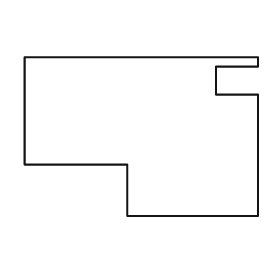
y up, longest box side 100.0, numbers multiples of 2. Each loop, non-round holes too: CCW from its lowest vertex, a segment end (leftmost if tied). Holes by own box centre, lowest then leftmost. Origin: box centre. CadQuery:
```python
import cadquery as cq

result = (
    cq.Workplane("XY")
    .moveTo(-6.0, -34.0)
    .lineTo(50.0, -34.0)
    .lineTo(50.0, 18.0)
    .lineTo(32.0, 18.0)
    .lineTo(32.0, 30.0)
    .lineTo(50.0, 30.0)
    .lineTo(50.0, 34.0)
    .lineTo(-50.0, 34.0)
    .lineTo(-50.0, -12.0)
    .lineTo(-6.0, -12.0)
    .close()
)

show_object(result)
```